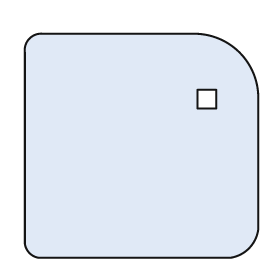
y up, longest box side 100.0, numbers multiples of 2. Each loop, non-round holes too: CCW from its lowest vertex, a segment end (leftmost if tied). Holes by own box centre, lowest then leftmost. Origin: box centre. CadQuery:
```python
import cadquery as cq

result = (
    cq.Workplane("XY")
    .moveTo(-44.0, -48.0)
    .lineTo(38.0, -48.0)
    .threePointArc((46.0, -44.0), (50.0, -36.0))
    .lineTo(50.0, 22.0)
    .threePointArc((42.0, 40.0), (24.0, 48.0))
    .lineTo(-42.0, 48.0)
    .threePointArc((-48.0, 46.0), (-50.0, 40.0))
    .lineTo(-50.0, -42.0)
    .threePointArc((-48.0, -46.0), (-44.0, -48.0))
    .close()
    .moveTo(24.0, 16.0)
    .lineTo(32.0, 16.0)
    .lineTo(32.0, 24.0)
    .lineTo(24.0, 24.0)
    .close()
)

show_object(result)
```